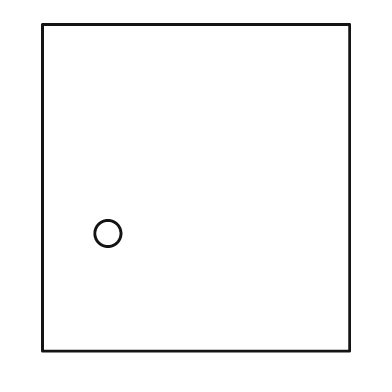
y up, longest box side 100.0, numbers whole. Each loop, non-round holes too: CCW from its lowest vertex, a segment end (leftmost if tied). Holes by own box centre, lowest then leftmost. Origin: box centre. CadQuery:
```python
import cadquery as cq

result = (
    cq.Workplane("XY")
    .moveTo(-47.0, -50.0)
    .lineTo(47.0, -50.0)
    .lineTo(47.0, 50.0)
    .lineTo(-47.0, 50.0)
    .close()
    .moveTo(-27.0, -14.0)
    .circle(4.0)
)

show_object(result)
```